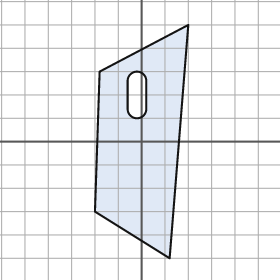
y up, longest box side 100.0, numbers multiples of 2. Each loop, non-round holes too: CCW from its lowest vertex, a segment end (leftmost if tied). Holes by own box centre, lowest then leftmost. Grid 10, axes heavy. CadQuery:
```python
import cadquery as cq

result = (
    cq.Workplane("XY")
    .moveTo(12.0, -50.0)
    .lineTo(20.0, 50.0)
    .lineTo(-18.0, 30.0)
    .lineTo(-20.0, -30.0)
    .close()
    .moveTo(-6.0, 14.0)
    .threePointArc((-2.0, 10.0), (2.0, 14.0))
    .lineTo(2.0, 26.0)
    .threePointArc((-2.0, 30.0), (-6.0, 26.0))
    .close()
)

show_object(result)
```